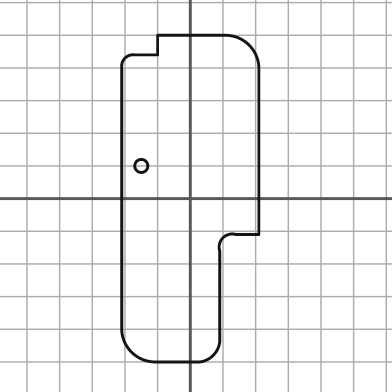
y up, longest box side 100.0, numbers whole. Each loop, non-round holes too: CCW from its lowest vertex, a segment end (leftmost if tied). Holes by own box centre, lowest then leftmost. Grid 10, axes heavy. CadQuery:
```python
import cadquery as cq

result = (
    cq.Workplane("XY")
    .moveTo(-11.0, -50.0)
    .lineTo(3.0, -50.0)
    .threePointArc((7.0, -48.0), (9.0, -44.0))
    .lineTo(9.0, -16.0)
    .threePointArc((10.0, -12.0), (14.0, -11.0))
    .lineTo(21.0, -11.0)
    .lineTo(21.0, 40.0)
    .threePointArc((18.0, 47.0), (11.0, 50.0))
    .lineTo(-10.0, 50.0)
    .lineTo(-10.0, 44.0)
    .lineTo(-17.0, 44.0)
    .threePointArc((-20.0, 43.0), (-21.0, 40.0))
    .lineTo(-21.0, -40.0)
    .threePointArc((-18.0, -47.0), (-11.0, -50.0))
    .close()
    .moveTo(-15.0, 10.0)
    .circle(2.0)
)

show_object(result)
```